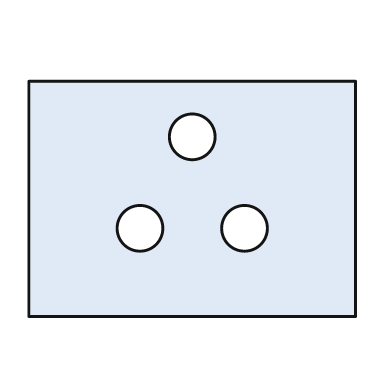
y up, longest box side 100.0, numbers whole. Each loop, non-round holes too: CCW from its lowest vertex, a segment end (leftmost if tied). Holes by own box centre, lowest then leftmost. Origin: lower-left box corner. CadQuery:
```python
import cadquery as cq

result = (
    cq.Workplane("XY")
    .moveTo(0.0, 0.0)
    .lineTo(100.0, 0.0)
    .lineTo(100.0, 72.0)
    .lineTo(0.0, 72.0)
    .close()
    .moveTo(34.0, 27.0)
    .circle(7.0)
    .moveTo(66.0, 27.0)
    .circle(7.0)
    .moveTo(50.0, 55.0)
    .circle(7.0)
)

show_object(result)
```